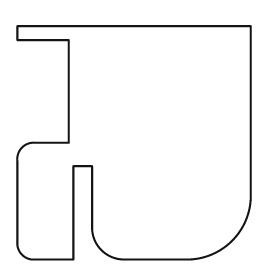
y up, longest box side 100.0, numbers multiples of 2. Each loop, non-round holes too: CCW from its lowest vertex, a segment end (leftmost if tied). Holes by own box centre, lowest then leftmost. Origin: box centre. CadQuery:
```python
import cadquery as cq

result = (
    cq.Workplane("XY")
    .moveTo(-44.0, -50.0)
    .lineTo(-26.0, -50.0)
    .lineTo(-26.0, -10.0)
    .lineTo(-18.0, -10.0)
    .lineTo(-18.0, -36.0)
    .threePointArc((-14.0, -46.0), (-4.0, -50.0))
    .lineTo(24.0, -50.0)
    .threePointArc((42.0, -42.0), (50.0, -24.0))
    .lineTo(50.0, 50.0)
    .lineTo(-50.0, 50.0)
    .lineTo(-50.0, 44.0)
    .lineTo(-28.0, 44.0)
    .lineTo(-28.0, 0.0)
    .lineTo(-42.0, 0.0)
    .threePointArc((-48.0, -2.0), (-50.0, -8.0))
    .lineTo(-50.0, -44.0)
    .threePointArc((-48.0, -48.0), (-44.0, -50.0))
    .close()
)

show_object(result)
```